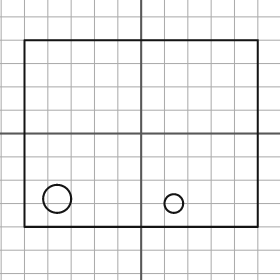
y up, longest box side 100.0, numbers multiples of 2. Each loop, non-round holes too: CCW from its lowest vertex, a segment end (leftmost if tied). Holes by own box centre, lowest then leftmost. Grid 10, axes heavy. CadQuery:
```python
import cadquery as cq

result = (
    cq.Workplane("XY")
    .moveTo(-50.0, -40.0)
    .lineTo(50.0, -40.0)
    .lineTo(50.0, 40.0)
    .lineTo(-50.0, 40.0)
    .close()
    .moveTo(14.0, -30.0)
    .circle(4.0)
    .moveTo(-36.0, -28.0)
    .circle(6.0)
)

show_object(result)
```